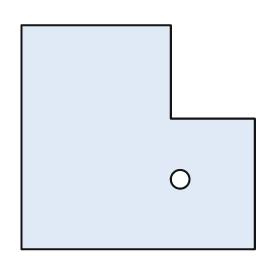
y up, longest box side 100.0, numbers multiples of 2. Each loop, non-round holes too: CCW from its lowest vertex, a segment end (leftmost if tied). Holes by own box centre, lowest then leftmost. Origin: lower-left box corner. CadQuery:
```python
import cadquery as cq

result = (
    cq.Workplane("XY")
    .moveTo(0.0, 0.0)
    .lineTo(100.0, 0.0)
    .lineTo(100.0, 56.0)
    .lineTo(64.0, 56.0)
    .lineTo(64.0, 96.0)
    .lineTo(0.0, 96.0)
    .close()
    .moveTo(68.0, 30.0)
    .circle(4.0)
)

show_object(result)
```